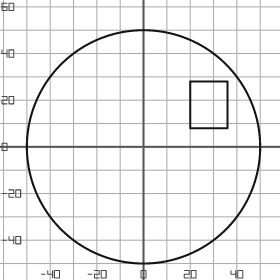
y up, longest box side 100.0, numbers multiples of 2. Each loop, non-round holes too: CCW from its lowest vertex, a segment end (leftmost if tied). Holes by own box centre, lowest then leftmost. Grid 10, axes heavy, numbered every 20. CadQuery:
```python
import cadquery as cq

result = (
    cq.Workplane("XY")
    .moveTo(0.0, 0.0)
    .circle(50.0)
    .moveTo(20.0, 8.0)
    .lineTo(36.0, 8.0)
    .lineTo(36.0, 28.0)
    .lineTo(20.0, 28.0)
    .close()
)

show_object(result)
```